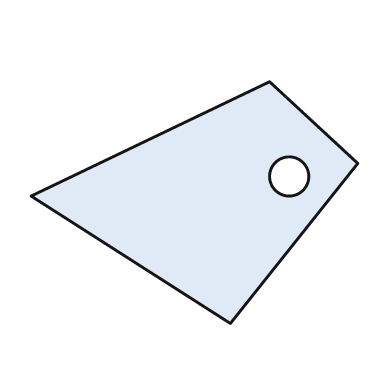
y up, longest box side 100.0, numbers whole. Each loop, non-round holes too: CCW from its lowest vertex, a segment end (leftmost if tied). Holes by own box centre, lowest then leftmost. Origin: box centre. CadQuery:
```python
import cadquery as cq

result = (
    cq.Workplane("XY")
    .moveTo(11.0, -37.0)
    .lineTo(50.0, 12.0)
    .lineTo(23.0, 37.0)
    .lineTo(-50.0, 2.0)
    .close()
    .moveTo(29.0, 8.0)
    .circle(6.0)
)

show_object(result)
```